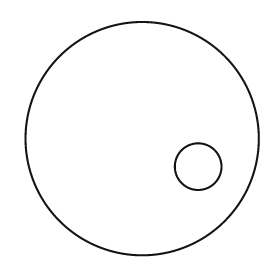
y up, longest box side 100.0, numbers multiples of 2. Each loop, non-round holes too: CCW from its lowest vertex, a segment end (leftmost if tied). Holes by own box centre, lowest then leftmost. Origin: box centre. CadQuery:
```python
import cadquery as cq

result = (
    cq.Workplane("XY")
    .moveTo(0.0, 0.0)
    .circle(50.0)
    .moveTo(24.0, -12.0)
    .circle(10.0)
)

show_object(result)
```